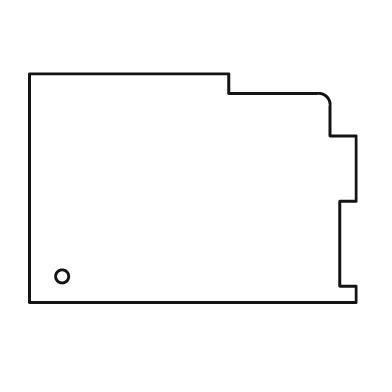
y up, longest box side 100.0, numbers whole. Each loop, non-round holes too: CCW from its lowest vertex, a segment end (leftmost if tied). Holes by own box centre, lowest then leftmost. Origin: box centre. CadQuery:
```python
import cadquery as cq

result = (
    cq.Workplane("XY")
    .moveTo(-50.0, -35.0)
    .lineTo(50.0, -35.0)
    .lineTo(50.0, -30.0)
    .lineTo(45.0, -30.0)
    .lineTo(45.0, -4.0)
    .lineTo(50.0, -4.0)
    .lineTo(50.0, 16.0)
    .lineTo(42.0, 16.0)
    .lineTo(42.0, 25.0)
    .threePointArc((41.0, 28.0), (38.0, 29.0))
    .lineTo(11.0, 29.0)
    .lineTo(11.0, 35.0)
    .lineTo(-50.0, 35.0)
    .close()
    .moveTo(-40.0, -27.0)
    .circle(2.0)
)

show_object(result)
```